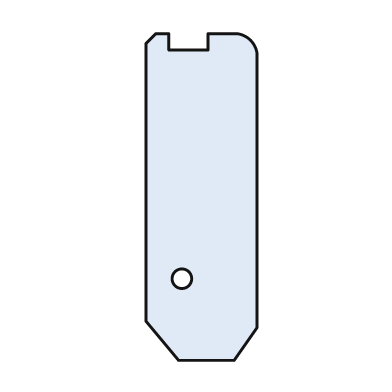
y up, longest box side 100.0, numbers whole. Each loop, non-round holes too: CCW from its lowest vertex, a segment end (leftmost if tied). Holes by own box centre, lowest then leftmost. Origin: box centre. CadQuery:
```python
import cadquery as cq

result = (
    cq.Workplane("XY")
    .moveTo(-7.0, -50.0)
    .lineTo(10.0, -50.0)
    .lineTo(17.0, -40.0)
    .lineTo(17.0, 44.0)
    .threePointArc((15.0, 48.0), (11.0, 50.0))
    .lineTo(2.0, 50.0)
    .lineTo(2.0, 45.0)
    .lineTo(-10.0, 45.0)
    .lineTo(-10.0, 50.0)
    .lineTo(-14.0, 50.0)
    .lineTo(-17.0, 47.0)
    .lineTo(-17.0, -38.0)
    .close()
    .moveTo(-6.0, -25.0)
    .circle(3.0)
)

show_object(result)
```